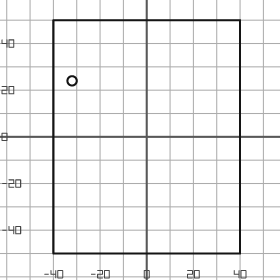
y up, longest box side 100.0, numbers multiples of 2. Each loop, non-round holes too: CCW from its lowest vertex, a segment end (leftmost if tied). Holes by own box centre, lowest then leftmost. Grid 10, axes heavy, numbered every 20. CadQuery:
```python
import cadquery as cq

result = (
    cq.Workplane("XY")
    .moveTo(-40.0, -50.0)
    .lineTo(40.0, -50.0)
    .lineTo(40.0, 50.0)
    .lineTo(-40.0, 50.0)
    .close()
    .moveTo(-32.0, 24.0)
    .circle(2.0)
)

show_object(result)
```